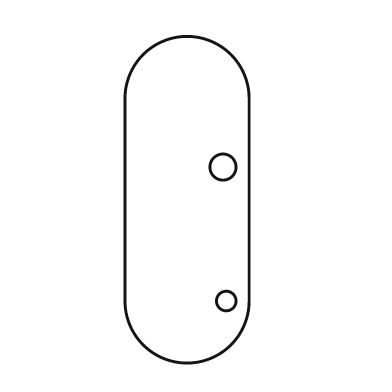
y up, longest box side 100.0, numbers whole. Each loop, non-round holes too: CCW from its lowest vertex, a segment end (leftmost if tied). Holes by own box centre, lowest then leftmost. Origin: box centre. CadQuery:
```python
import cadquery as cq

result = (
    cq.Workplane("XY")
    .moveTo(-19.0, -31.0)
    .threePointArc((0.0, -50.0), (19.0, -31.0))
    .lineTo(19.0, 31.0)
    .threePointArc((0.0, 50.0), (-19.0, 31.0))
    .close()
    .moveTo(12.0, -31.0)
    .circle(3.0)
    .moveTo(11.0, 10.0)
    .circle(4.0)
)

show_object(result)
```